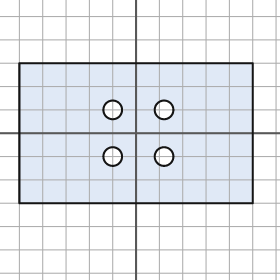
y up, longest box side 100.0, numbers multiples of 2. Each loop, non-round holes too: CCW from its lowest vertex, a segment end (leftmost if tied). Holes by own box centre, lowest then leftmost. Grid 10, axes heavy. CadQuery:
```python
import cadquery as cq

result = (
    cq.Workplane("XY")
    .moveTo(-50.0, -30.0)
    .lineTo(50.0, -30.0)
    .lineTo(50.0, 30.0)
    .lineTo(-50.0, 30.0)
    .close()
    .moveTo(-10.0, -10.0)
    .circle(4.0)
    .moveTo(12.0, -10.0)
    .circle(4.0)
    .moveTo(-10.0, 10.0)
    .circle(4.0)
    .moveTo(12.0, 10.0)
    .circle(4.0)
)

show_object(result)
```